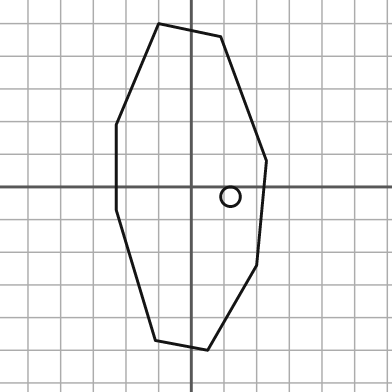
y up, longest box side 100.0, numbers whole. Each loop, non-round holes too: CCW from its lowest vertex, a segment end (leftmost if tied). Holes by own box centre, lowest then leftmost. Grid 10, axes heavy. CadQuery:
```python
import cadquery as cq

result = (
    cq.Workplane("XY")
    .moveTo(5.0, -50.0)
    .lineTo(20.0, -24.0)
    .lineTo(23.0, 8.0)
    .lineTo(9.0, 46.0)
    .lineTo(-10.0, 50.0)
    .lineTo(-23.0, 19.0)
    .lineTo(-23.0, -7.0)
    .lineTo(-11.0, -47.0)
    .close()
    .moveTo(12.0, -3.0)
    .circle(3.0)
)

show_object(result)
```